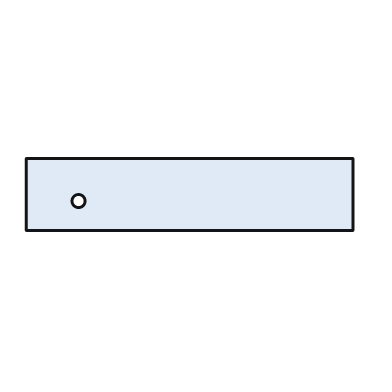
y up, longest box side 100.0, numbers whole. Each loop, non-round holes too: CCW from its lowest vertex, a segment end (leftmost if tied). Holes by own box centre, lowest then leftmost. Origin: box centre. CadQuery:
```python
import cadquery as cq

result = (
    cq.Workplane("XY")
    .moveTo(-50.0, -11.0)
    .lineTo(50.0, -11.0)
    .lineTo(50.0, 11.0)
    .lineTo(-50.0, 11.0)
    .close()
    .moveTo(-34.0, -2.0)
    .circle(2.0)
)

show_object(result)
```